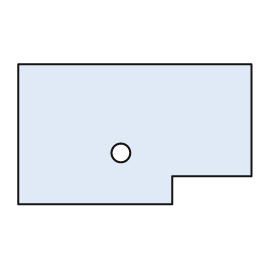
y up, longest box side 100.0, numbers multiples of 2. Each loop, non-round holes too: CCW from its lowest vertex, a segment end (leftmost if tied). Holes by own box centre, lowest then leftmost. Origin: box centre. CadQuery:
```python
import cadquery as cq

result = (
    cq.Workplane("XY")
    .moveTo(-50.0, -30.0)
    .lineTo(16.0, -30.0)
    .lineTo(16.0, -18.0)
    .lineTo(50.0, -18.0)
    .lineTo(50.0, 30.0)
    .lineTo(-50.0, 30.0)
    .close()
    .moveTo(-6.0, -8.0)
    .circle(4.0)
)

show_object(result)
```